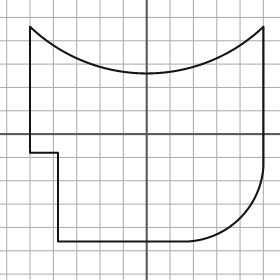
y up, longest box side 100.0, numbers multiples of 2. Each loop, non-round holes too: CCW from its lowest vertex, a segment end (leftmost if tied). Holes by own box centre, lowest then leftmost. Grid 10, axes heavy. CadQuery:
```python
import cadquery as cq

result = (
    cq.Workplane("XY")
    .moveTo(-38.0, -46.0)
    .lineTo(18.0, -46.0)
    .threePointArc((40.0, -36.0), (50.0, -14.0))
    .lineTo(50.0, 46.0)
    .threePointArc((0.0, 26.0), (-50.0, 46.0))
    .lineTo(-50.0, -8.0)
    .lineTo(-38.0, -8.0)
    .close()
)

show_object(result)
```